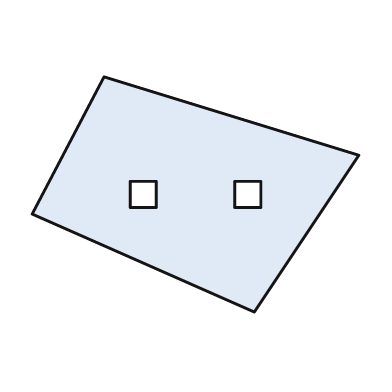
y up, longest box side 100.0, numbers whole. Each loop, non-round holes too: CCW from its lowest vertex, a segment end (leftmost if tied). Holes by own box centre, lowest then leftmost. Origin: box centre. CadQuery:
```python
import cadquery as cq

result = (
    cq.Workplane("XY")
    .moveTo(18.0, -36.0)
    .lineTo(50.0, 12.0)
    .lineTo(-28.0, 36.0)
    .lineTo(-50.0, -6.0)
    .close()
    .moveTo(-20.0, -4.0)
    .lineTo(-12.0, -4.0)
    .lineTo(-12.0, 4.0)
    .lineTo(-20.0, 4.0)
    .close()
    .moveTo(12.0, -4.0)
    .lineTo(20.0, -4.0)
    .lineTo(20.0, 4.0)
    .lineTo(12.0, 4.0)
    .close()
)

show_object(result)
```